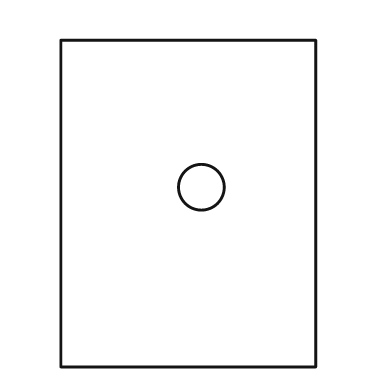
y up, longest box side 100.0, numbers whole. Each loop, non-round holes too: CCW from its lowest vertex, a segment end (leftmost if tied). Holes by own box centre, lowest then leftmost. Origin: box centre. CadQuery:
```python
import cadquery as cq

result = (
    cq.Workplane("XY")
    .moveTo(-39.0, -50.0)
    .lineTo(39.0, -50.0)
    .lineTo(39.0, 50.0)
    .lineTo(-39.0, 50.0)
    .close()
    .moveTo(4.0, 5.0)
    .circle(7.0)
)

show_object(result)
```